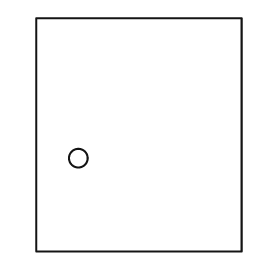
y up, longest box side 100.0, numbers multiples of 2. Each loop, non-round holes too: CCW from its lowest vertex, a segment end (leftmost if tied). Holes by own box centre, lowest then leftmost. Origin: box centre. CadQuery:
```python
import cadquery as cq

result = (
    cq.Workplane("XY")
    .moveTo(-44.0, -50.0)
    .lineTo(44.0, -50.0)
    .lineTo(44.0, 50.0)
    .lineTo(-44.0, 50.0)
    .close()
    .moveTo(-26.0, -10.0)
    .circle(4.0)
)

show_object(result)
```